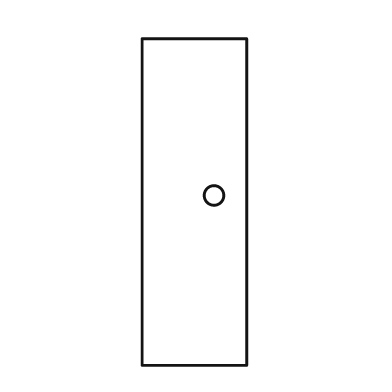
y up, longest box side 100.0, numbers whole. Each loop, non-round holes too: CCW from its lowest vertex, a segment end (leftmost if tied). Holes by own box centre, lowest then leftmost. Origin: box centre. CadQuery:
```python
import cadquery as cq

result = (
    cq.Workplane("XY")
    .moveTo(-16.0, -50.0)
    .lineTo(16.0, -50.0)
    .lineTo(16.0, 50.0)
    .lineTo(-16.0, 50.0)
    .close()
    .moveTo(6.0, 2.0)
    .circle(3.0)
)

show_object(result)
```